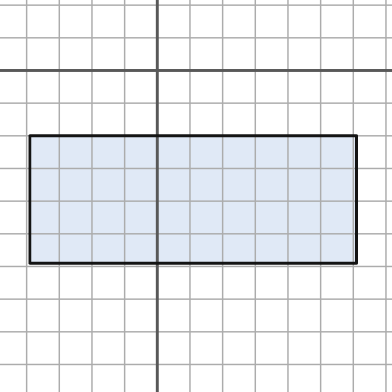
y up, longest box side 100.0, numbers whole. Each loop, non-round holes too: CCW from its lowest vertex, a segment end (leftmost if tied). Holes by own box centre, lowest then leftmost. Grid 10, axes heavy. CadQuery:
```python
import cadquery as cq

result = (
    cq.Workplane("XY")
    .moveTo(-39.0, -59.0)
    .lineTo(61.0, -59.0)
    .lineTo(61.0, -20.0)
    .lineTo(-39.0, -20.0)
    .close()
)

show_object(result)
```